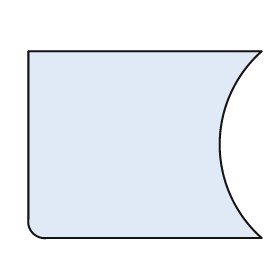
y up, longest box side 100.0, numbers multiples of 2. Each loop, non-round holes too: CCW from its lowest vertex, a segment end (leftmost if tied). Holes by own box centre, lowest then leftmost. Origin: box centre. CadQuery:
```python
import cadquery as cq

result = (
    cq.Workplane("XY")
    .moveTo(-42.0, -40.0)
    .lineTo(50.0, -40.0)
    .threePointArc((32.0, 0.0), (50.0, 40.0))
    .lineTo(-50.0, 40.0)
    .lineTo(-50.0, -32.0)
    .threePointArc((-48.0, -38.0), (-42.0, -40.0))
    .close()
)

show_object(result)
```